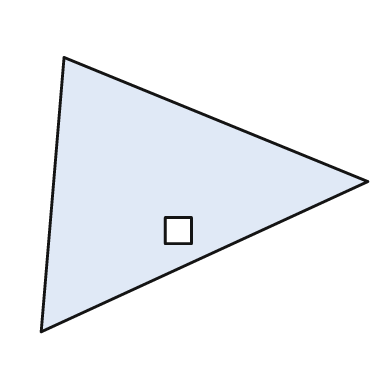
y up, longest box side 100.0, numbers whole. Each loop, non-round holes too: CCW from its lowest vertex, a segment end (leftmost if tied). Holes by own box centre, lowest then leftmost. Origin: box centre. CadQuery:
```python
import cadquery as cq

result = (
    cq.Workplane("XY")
    .moveTo(-50.0, -42.0)
    .lineTo(50.0, 4.0)
    .lineTo(-43.0, 42.0)
    .close()
    .moveTo(-12.0, -15.0)
    .lineTo(-4.0, -15.0)
    .lineTo(-4.0, -7.0)
    .lineTo(-12.0, -7.0)
    .close()
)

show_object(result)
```